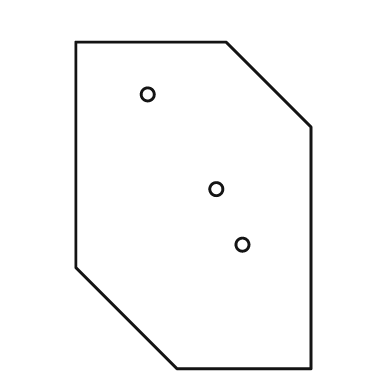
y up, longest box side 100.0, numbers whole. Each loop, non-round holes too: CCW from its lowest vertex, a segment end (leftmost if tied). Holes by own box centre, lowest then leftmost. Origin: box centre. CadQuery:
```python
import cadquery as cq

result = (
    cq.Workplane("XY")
    .moveTo(-5.0, -50.0)
    .lineTo(36.0, -50.0)
    .lineTo(36.0, 24.0)
    .lineTo(10.0, 50.0)
    .lineTo(-36.0, 50.0)
    .lineTo(-36.0, -19.0)
    .close()
    .moveTo(15.0, -12.0)
    .circle(2.0)
    .moveTo(7.0, 5.0)
    .circle(2.0)
    .moveTo(-14.0, 34.0)
    .circle(2.0)
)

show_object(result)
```